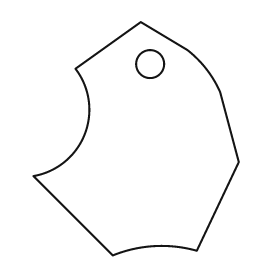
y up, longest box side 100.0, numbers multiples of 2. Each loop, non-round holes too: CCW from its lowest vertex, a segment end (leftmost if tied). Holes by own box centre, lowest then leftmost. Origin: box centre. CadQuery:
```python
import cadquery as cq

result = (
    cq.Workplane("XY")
    .moveTo(-10.0, -50.0)
    .threePointArc((8.0, -46.0), (26.0, -48.0))
    .lineTo(44.0, -10.0)
    .lineTo(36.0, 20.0)
    .threePointArc((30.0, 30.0), (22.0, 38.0))
    .lineTo(2.0, 50.0)
    .lineTo(-26.0, 30.0)
    .threePointArc((-22.0, 2.0), (-44.0, -16.0))
    .close()
    .moveTo(6.0, 32.0)
    .circle(6.0)
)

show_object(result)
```